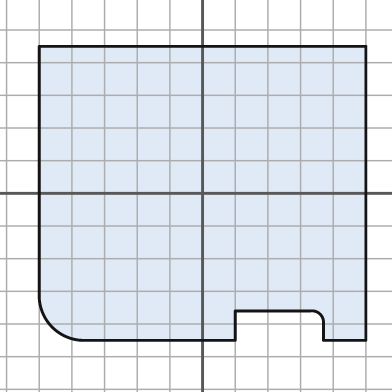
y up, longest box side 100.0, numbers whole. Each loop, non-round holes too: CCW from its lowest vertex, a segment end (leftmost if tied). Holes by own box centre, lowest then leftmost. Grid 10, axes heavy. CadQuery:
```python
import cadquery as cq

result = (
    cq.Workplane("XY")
    .moveTo(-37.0, -45.0)
    .lineTo(10.0, -45.0)
    .lineTo(10.0, -36.0)
    .lineTo(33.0, -36.0)
    .threePointArc((36.0, -37.0), (37.0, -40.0))
    .lineTo(37.0, -45.0)
    .lineTo(50.0, -45.0)
    .lineTo(50.0, 45.0)
    .lineTo(-50.0, 45.0)
    .lineTo(-50.0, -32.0)
    .threePointArc((-46.0, -41.0), (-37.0, -45.0))
    .close()
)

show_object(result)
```